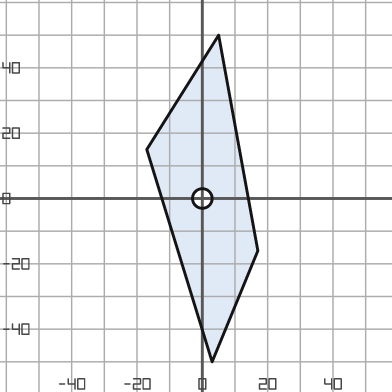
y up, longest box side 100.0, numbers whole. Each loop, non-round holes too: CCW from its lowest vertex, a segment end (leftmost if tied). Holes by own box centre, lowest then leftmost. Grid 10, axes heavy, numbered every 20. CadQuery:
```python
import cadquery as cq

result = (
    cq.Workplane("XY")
    .moveTo(3.0, -50.0)
    .lineTo(17.0, -16.0)
    .lineTo(5.0, 50.0)
    .lineTo(-17.0, 15.0)
    .close()
    .moveTo(0.0, 0.0)
    .circle(3.0)
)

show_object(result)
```